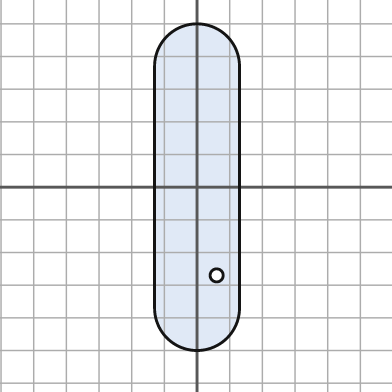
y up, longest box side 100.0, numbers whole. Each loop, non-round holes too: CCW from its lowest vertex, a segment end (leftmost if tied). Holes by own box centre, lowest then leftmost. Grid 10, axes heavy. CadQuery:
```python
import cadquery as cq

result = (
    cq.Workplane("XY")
    .moveTo(-13.0, -37.0)
    .threePointArc((0.0, -50.0), (13.0, -37.0))
    .lineTo(13.0, 37.0)
    .threePointArc((0.0, 50.0), (-13.0, 37.0))
    .close()
    .moveTo(6.0, -27.0)
    .circle(2.0)
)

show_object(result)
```